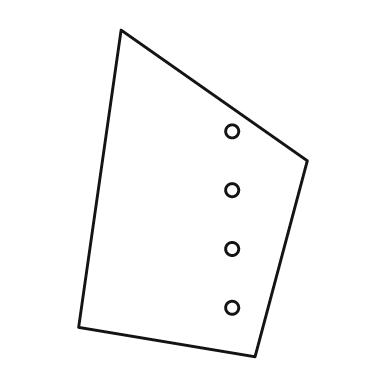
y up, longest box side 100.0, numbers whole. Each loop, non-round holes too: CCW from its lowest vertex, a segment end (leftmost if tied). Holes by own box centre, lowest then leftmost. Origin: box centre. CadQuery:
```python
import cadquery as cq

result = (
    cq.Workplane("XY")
    .moveTo(19.0, -50.0)
    .lineTo(35.0, 10.0)
    .lineTo(-22.0, 50.0)
    .lineTo(-35.0, -41.0)
    .close()
    .moveTo(12.0, -35.0)
    .circle(2.0)
    .moveTo(12.0, -17.0)
    .circle(2.0)
    .moveTo(12.0, 1.0)
    .circle(2.0)
    .moveTo(12.0, 19.0)
    .circle(2.0)
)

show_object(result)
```